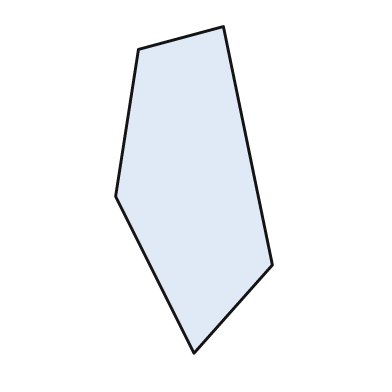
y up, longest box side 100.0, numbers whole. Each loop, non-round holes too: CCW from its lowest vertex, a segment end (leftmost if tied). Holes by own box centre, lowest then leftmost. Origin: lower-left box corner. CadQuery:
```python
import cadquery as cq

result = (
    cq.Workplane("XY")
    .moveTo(24.0, 0.0)
    .lineTo(48.0, 27.0)
    .lineTo(33.0, 100.0)
    .lineTo(7.0, 93.0)
    .lineTo(0.0, 48.0)
    .close()
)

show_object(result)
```